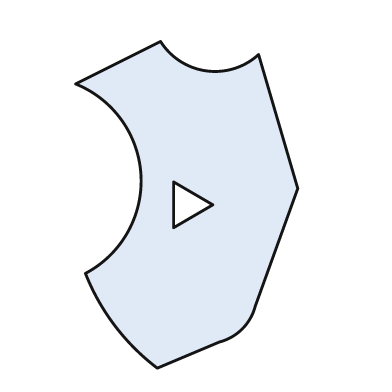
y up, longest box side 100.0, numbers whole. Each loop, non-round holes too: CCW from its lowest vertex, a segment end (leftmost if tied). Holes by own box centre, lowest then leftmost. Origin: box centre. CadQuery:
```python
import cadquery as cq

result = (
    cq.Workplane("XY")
    .moveTo(-9.0, -50.0)
    .lineTo(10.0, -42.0)
    .threePointArc((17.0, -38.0), (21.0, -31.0))
    .lineTo(34.0, 5.0)
    .lineTo(22.0, 46.0)
    .threePointArc((6.0, 41.0), (-8.0, 50.0))
    .lineTo(-34.0, 37.0)
    .threePointArc((-14.0, 9.0), (-31.0, -21.0))
    .threePointArc((-22.0, -37.0), (-9.0, -50.0))
    .close()
    .moveTo(-4.0, -7.0)
    .lineTo(8.0, 0.0)
    .lineTo(-4.0, 7.0)
    .close()
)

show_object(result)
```